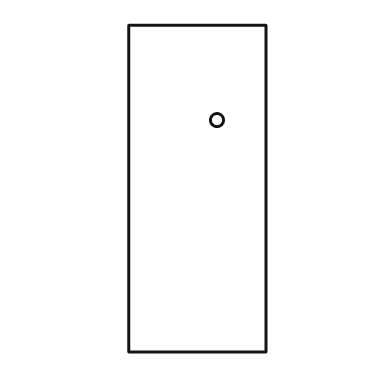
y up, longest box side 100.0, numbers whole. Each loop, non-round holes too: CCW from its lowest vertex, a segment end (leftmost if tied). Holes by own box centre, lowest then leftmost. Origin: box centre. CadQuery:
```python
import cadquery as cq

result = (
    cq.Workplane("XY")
    .moveTo(-21.0, -50.0)
    .lineTo(21.0, -50.0)
    .lineTo(21.0, 50.0)
    .lineTo(-21.0, 50.0)
    .close()
    .moveTo(6.0, 21.0)
    .circle(2.0)
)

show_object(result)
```